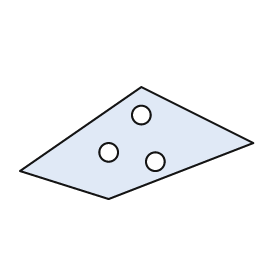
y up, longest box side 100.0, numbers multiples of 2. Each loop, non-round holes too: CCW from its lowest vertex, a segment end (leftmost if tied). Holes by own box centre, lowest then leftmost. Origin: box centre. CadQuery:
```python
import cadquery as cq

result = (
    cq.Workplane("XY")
    .moveTo(-12.0, -24.0)
    .lineTo(50.0, 0.0)
    .lineTo(2.0, 24.0)
    .lineTo(-50.0, -12.0)
    .close()
    .moveTo(8.0, -8.0)
    .circle(4.0)
    .moveTo(-12.0, -4.0)
    .circle(4.0)
    .moveTo(2.0, 12.0)
    .circle(4.0)
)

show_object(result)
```